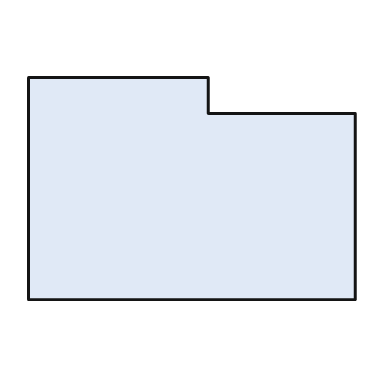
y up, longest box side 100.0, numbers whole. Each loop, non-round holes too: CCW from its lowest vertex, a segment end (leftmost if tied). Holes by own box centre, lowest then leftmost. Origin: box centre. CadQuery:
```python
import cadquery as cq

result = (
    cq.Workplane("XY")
    .moveTo(-50.0, -34.0)
    .lineTo(50.0, -34.0)
    .lineTo(50.0, 23.0)
    .lineTo(5.0, 23.0)
    .lineTo(5.0, 34.0)
    .lineTo(-50.0, 34.0)
    .close()
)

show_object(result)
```